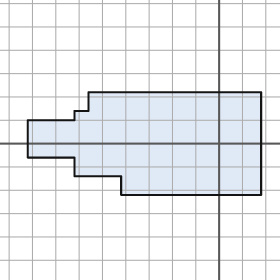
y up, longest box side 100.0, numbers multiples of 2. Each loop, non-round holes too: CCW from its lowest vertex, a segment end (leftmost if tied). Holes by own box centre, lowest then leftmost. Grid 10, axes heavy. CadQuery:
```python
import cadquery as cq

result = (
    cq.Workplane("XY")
    .moveTo(-42.0, -22.0)
    .lineTo(18.0, -22.0)
    .lineTo(18.0, 22.0)
    .lineTo(-56.0, 22.0)
    .lineTo(-56.0, 14.0)
    .lineTo(-62.0, 14.0)
    .lineTo(-62.0, 10.0)
    .lineTo(-82.0, 10.0)
    .lineTo(-82.0, -6.0)
    .lineTo(-62.0, -6.0)
    .lineTo(-62.0, -14.0)
    .lineTo(-42.0, -14.0)
    .close()
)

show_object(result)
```